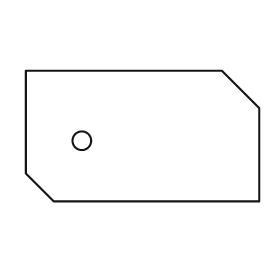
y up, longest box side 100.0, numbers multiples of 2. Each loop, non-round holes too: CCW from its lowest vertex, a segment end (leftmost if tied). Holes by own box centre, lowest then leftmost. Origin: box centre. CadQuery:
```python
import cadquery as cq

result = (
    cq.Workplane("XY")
    .moveTo(-38.0, -28.0)
    .lineTo(50.0, -28.0)
    .lineTo(50.0, 12.0)
    .lineTo(34.0, 28.0)
    .lineTo(-50.0, 28.0)
    .lineTo(-50.0, -16.0)
    .close()
    .moveTo(-26.0, -2.0)
    .circle(4.0)
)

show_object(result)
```